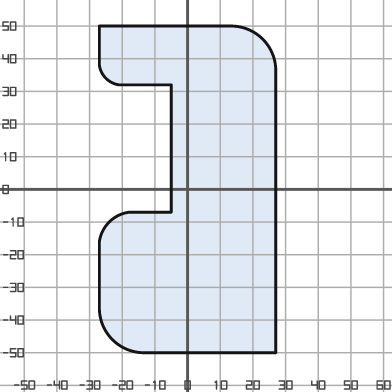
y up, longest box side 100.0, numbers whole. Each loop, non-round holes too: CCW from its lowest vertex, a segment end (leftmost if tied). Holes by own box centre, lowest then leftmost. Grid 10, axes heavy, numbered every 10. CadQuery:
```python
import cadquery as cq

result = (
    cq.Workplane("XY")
    .moveTo(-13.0, -50.0)
    .lineTo(27.0, -50.0)
    .lineTo(27.0, 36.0)
    .threePointArc((23.0, 46.0), (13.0, 50.0))
    .lineTo(-27.0, 50.0)
    .lineTo(-27.0, 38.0)
    .threePointArc((-25.0, 34.0), (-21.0, 32.0))
    .lineTo(-5.0, 32.0)
    .lineTo(-5.0, -7.0)
    .lineTo(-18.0, -7.0)
    .threePointArc((-24.0, -10.0), (-27.0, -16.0))
    .lineTo(-27.0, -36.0)
    .threePointArc((-23.0, -46.0), (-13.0, -50.0))
    .close()
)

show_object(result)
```